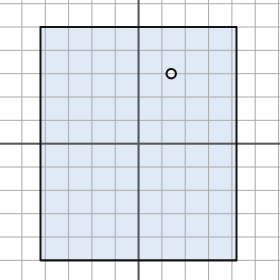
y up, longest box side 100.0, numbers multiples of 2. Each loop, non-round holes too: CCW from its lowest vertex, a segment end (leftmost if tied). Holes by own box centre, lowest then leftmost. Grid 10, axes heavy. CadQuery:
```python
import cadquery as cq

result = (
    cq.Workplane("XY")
    .moveTo(-42.0, -50.0)
    .lineTo(42.0, -50.0)
    .lineTo(42.0, 50.0)
    .lineTo(-42.0, 50.0)
    .close()
    .moveTo(14.0, 30.0)
    .circle(2.0)
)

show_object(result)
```